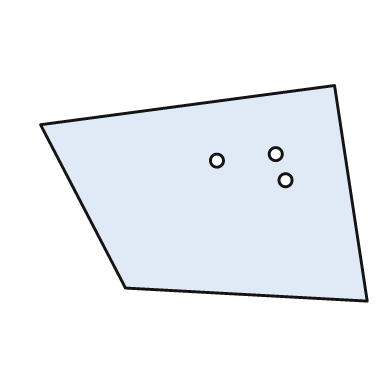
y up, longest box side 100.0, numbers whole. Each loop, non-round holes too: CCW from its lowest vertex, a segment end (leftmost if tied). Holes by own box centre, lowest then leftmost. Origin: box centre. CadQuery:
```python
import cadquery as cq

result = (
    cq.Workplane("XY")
    .moveTo(50.0, -33.0)
    .lineTo(40.0, 33.0)
    .lineTo(-50.0, 21.0)
    .lineTo(-24.0, -29.0)
    .close()
    .moveTo(25.0, 4.0)
    .circle(2.0)
    .moveTo(4.0, 10.0)
    .circle(2.0)
    .moveTo(22.0, 12.0)
    .circle(2.0)
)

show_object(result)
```